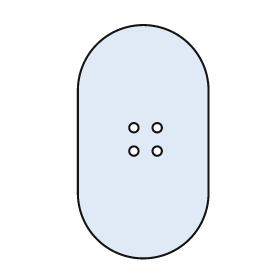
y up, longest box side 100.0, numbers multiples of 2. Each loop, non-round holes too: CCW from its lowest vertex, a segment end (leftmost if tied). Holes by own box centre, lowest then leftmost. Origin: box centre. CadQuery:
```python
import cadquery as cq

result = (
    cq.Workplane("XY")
    .moveTo(-28.0, -22.0)
    .threePointArc((0.0, -50.0), (28.0, -22.0))
    .lineTo(28.0, 22.0)
    .threePointArc((0.0, 50.0), (-28.0, 22.0))
    .close()
    .moveTo(-4.0, -4.0)
    .circle(2.0)
    .moveTo(6.0, -4.0)
    .circle(2.0)
    .moveTo(-4.0, 6.0)
    .circle(2.0)
    .moveTo(6.0, 6.0)
    .circle(2.0)
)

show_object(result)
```